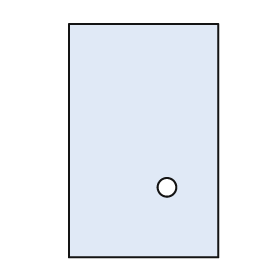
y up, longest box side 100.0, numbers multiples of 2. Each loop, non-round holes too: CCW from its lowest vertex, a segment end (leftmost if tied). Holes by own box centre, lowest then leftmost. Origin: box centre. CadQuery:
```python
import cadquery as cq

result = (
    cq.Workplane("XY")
    .moveTo(-32.0, -50.0)
    .lineTo(32.0, -50.0)
    .lineTo(32.0, 50.0)
    .lineTo(-32.0, 50.0)
    .close()
    .moveTo(10.0, -20.0)
    .circle(4.0)
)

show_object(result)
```